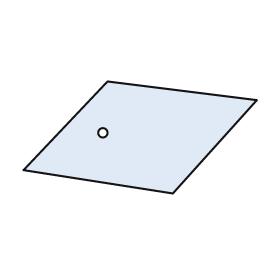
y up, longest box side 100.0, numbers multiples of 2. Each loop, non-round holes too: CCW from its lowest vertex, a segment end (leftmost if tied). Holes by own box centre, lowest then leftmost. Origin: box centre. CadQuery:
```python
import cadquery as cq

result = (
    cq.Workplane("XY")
    .moveTo(14.0, -24.0)
    .lineTo(50.0, 16.0)
    .lineTo(-14.0, 24.0)
    .lineTo(-50.0, -14.0)
    .close()
    .moveTo(-16.0, 2.0)
    .circle(2.0)
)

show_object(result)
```